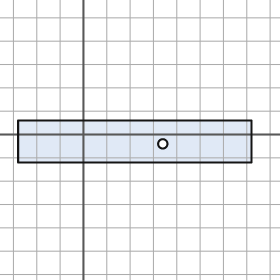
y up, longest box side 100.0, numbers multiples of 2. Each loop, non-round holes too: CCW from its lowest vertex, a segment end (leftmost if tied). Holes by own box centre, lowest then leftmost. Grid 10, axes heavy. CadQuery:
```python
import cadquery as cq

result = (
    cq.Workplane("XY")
    .moveTo(-28.0, -12.0)
    .lineTo(72.0, -12.0)
    .lineTo(72.0, 6.0)
    .lineTo(-28.0, 6.0)
    .close()
    .moveTo(34.0, -4.0)
    .circle(2.0)
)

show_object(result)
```